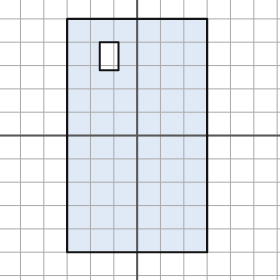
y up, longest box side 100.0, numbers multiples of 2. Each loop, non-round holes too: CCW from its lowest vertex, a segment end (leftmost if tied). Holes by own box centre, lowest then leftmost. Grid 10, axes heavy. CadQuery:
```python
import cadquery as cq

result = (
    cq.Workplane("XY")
    .moveTo(-30.0, -50.0)
    .lineTo(30.0, -50.0)
    .lineTo(30.0, 50.0)
    .lineTo(-30.0, 50.0)
    .close()
    .moveTo(-16.0, 28.0)
    .lineTo(-8.0, 28.0)
    .lineTo(-8.0, 40.0)
    .lineTo(-16.0, 40.0)
    .close()
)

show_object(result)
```